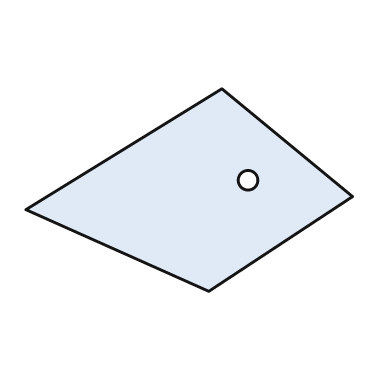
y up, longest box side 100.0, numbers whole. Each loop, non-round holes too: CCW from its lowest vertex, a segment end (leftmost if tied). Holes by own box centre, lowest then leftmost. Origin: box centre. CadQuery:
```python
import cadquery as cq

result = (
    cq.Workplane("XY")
    .moveTo(6.0, -31.0)
    .lineTo(50.0, -2.0)
    .lineTo(10.0, 31.0)
    .lineTo(-50.0, -6.0)
    .close()
    .moveTo(18.0, 3.0)
    .circle(3.0)
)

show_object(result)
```